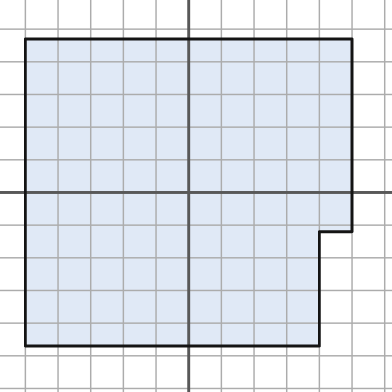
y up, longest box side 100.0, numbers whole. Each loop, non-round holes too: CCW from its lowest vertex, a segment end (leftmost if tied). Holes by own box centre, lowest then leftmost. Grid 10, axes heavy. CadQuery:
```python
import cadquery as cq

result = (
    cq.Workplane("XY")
    .moveTo(-50.0, -47.0)
    .lineTo(40.0, -47.0)
    .lineTo(40.0, -12.0)
    .lineTo(50.0, -12.0)
    .lineTo(50.0, 47.0)
    .lineTo(-50.0, 47.0)
    .close()
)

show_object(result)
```